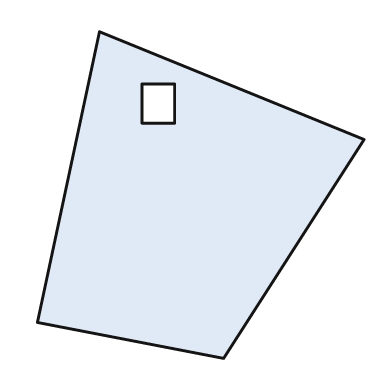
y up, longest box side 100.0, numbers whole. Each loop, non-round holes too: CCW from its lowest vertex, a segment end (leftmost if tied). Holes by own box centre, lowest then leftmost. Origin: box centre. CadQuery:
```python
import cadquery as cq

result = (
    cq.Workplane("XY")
    .moveTo(7.0, -50.0)
    .lineTo(50.0, 17.0)
    .lineTo(-31.0, 50.0)
    .lineTo(-50.0, -39.0)
    .close()
    .moveTo(-18.0, 22.0)
    .lineTo(-8.0, 22.0)
    .lineTo(-8.0, 34.0)
    .lineTo(-18.0, 34.0)
    .close()
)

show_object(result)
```